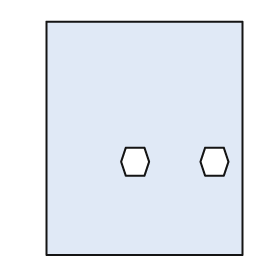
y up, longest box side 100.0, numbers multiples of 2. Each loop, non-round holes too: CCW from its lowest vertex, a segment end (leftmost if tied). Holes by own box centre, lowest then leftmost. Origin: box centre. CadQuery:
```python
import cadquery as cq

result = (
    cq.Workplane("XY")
    .moveTo(-42.0, -50.0)
    .lineTo(42.0, -50.0)
    .lineTo(42.0, 50.0)
    .lineTo(-42.0, 50.0)
    .close()
    .moveTo(-8.0, -16.0)
    .lineTo(0.0, -16.0)
    .lineTo(2.0, -10.0)
    .lineTo(0.0, -4.0)
    .lineTo(-8.0, -4.0)
    .lineTo(-10.0, -10.0)
    .close()
    .moveTo(26.0, -16.0)
    .lineTo(34.0, -16.0)
    .lineTo(36.0, -10.0)
    .lineTo(34.0, -4.0)
    .lineTo(26.0, -4.0)
    .lineTo(24.0, -10.0)
    .close()
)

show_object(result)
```